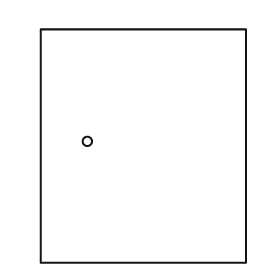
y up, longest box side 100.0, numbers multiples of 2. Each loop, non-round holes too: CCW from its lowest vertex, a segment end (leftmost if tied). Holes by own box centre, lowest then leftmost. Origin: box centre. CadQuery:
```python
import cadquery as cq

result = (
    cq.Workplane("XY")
    .moveTo(-44.0, -50.0)
    .lineTo(44.0, -50.0)
    .lineTo(44.0, 50.0)
    .lineTo(-44.0, 50.0)
    .close()
    .moveTo(-24.0, 2.0)
    .circle(2.0)
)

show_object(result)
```